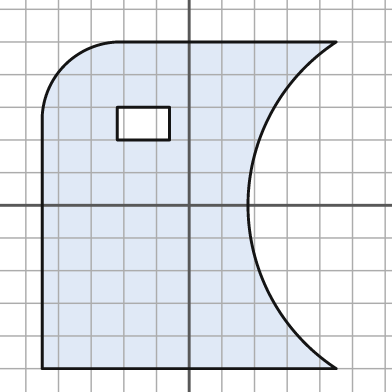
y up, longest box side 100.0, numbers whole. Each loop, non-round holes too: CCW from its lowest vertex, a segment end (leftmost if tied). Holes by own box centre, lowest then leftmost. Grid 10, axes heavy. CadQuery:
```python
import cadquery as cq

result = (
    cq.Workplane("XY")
    .moveTo(-45.0, -50.0)
    .lineTo(45.0, -50.0)
    .threePointArc((18.0, 0.0), (45.0, 50.0))
    .lineTo(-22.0, 50.0)
    .threePointArc((-38.0, 43.0), (-45.0, 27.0))
    .close()
    .moveTo(-22.0, 20.0)
    .lineTo(-6.0, 20.0)
    .lineTo(-6.0, 30.0)
    .lineTo(-22.0, 30.0)
    .close()
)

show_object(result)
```